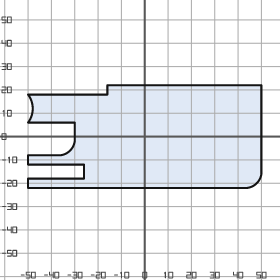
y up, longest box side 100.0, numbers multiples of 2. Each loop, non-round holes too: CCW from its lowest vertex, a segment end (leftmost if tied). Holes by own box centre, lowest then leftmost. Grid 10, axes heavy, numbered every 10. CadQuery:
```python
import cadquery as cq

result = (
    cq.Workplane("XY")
    .moveTo(-50.0, -22.0)
    .lineTo(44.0, -22.0)
    .threePointArc((48.0, -20.0), (50.0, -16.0))
    .lineTo(50.0, 22.0)
    .lineTo(-16.0, 22.0)
    .lineTo(-16.0, 18.0)
    .lineTo(-50.0, 18.0)
    .threePointArc((-48.0, 12.0), (-50.0, 6.0))
    .lineTo(-30.0, 6.0)
    .lineTo(-30.0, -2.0)
    .threePointArc((-32.0, -6.0), (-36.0, -8.0))
    .lineTo(-50.0, -8.0)
    .lineTo(-50.0, -12.0)
    .lineTo(-26.0, -12.0)
    .lineTo(-26.0, -18.0)
    .lineTo(-50.0, -18.0)
    .close()
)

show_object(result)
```